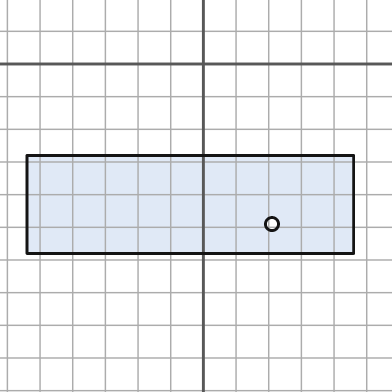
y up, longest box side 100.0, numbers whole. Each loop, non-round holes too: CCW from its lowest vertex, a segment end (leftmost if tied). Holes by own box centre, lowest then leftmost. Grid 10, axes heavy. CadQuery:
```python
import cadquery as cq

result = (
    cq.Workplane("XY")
    .moveTo(-54.0, -58.0)
    .lineTo(46.0, -58.0)
    .lineTo(46.0, -28.0)
    .lineTo(-54.0, -28.0)
    .close()
    .moveTo(21.0, -49.0)
    .circle(2.0)
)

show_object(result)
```